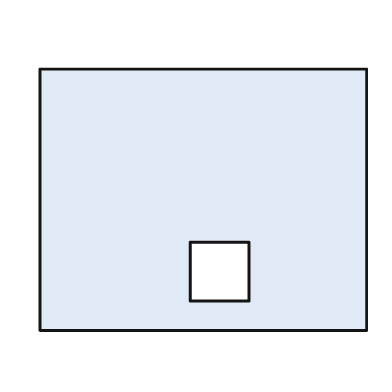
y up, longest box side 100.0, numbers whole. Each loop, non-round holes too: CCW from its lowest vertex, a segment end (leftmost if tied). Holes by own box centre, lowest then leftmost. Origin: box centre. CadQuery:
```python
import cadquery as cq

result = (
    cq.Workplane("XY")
    .moveTo(-50.0, -40.0)
    .lineTo(50.0, -40.0)
    .lineTo(50.0, 40.0)
    .lineTo(-50.0, 40.0)
    .close()
    .moveTo(-4.0, -31.0)
    .lineTo(14.0, -31.0)
    .lineTo(14.0, -13.0)
    .lineTo(-4.0, -13.0)
    .close()
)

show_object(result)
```